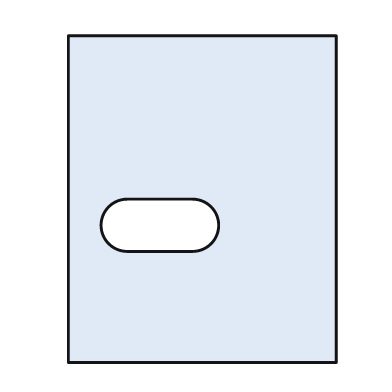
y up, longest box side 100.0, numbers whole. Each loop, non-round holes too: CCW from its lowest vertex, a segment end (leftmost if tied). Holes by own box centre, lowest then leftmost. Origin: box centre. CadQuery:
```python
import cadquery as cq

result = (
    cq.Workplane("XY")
    .moveTo(-41.0, -50.0)
    .lineTo(41.0, -50.0)
    .lineTo(41.0, 50.0)
    .lineTo(-41.0, 50.0)
    .close()
    .moveTo(-23.0, -16.0)
    .lineTo(-3.0, -16.0)
    .threePointArc((5.0, -8.0), (-3.0, 0.0))
    .lineTo(-23.0, 0.0)
    .threePointArc((-31.0, -8.0), (-23.0, -16.0))
    .close()
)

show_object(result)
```